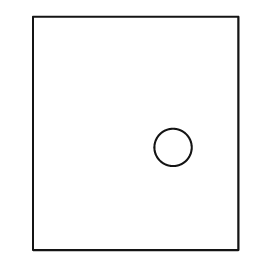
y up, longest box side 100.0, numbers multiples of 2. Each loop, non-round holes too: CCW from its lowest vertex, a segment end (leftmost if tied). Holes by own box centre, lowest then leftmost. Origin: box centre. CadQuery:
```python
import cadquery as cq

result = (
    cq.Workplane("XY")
    .moveTo(-44.0, -50.0)
    .lineTo(44.0, -50.0)
    .lineTo(44.0, 50.0)
    .lineTo(-44.0, 50.0)
    .close()
    .moveTo(16.0, -6.0)
    .circle(8.0)
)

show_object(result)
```